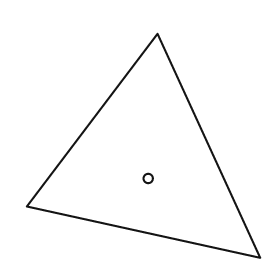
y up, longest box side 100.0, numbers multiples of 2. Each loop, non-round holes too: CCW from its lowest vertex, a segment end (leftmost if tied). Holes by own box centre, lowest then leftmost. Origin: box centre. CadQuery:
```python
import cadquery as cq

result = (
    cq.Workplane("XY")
    .moveTo(50.0, -48.0)
    .lineTo(6.0, 48.0)
    .lineTo(-50.0, -26.0)
    .close()
    .moveTo(2.0, -14.0)
    .circle(2.0)
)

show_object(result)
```